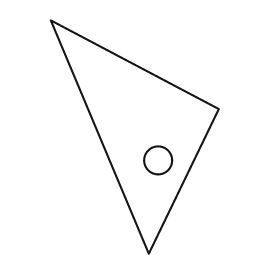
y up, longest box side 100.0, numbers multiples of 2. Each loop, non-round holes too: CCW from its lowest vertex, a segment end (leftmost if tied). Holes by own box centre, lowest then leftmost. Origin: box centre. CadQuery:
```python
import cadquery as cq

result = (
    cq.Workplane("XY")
    .moveTo(6.0, -50.0)
    .lineTo(36.0, 12.0)
    .lineTo(-36.0, 50.0)
    .close()
    .moveTo(10.0, -10.0)
    .circle(6.0)
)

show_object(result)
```